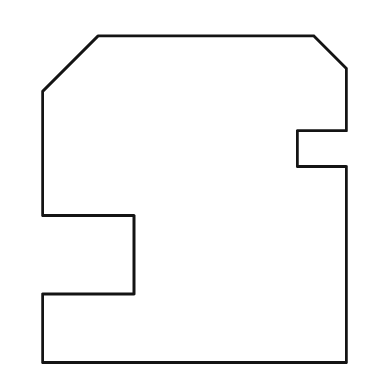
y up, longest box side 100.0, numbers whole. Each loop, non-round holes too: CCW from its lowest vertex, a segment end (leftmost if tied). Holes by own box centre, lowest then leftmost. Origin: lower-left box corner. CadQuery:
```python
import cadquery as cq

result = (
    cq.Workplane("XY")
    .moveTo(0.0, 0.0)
    .lineTo(93.0, 0.0)
    .lineTo(93.0, 60.0)
    .lineTo(78.0, 60.0)
    .lineTo(78.0, 71.0)
    .lineTo(93.0, 71.0)
    .lineTo(93.0, 90.0)
    .lineTo(83.0, 100.0)
    .lineTo(17.0, 100.0)
    .lineTo(0.0, 83.0)
    .lineTo(0.0, 45.0)
    .lineTo(28.0, 45.0)
    .lineTo(28.0, 21.0)
    .lineTo(0.0, 21.0)
    .close()
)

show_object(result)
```